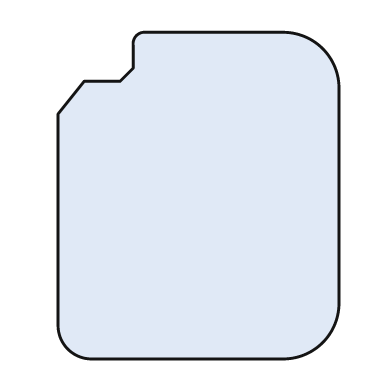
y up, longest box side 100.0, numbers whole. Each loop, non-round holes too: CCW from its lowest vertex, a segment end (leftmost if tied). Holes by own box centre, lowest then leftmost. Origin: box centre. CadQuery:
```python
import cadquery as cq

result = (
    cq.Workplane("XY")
    .moveTo(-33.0, -50.0)
    .lineTo(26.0, -50.0)
    .threePointArc((38.0, -45.0), (43.0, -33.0))
    .lineTo(43.0, 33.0)
    .threePointArc((38.0, 45.0), (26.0, 50.0))
    .lineTo(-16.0, 50.0)
    .threePointArc((-19.0, 49.0), (-20.0, 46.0))
    .lineTo(-20.0, 39.0)
    .lineTo(-24.0, 35.0)
    .lineTo(-35.0, 35.0)
    .lineTo(-43.0, 25.0)
    .lineTo(-43.0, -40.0)
    .threePointArc((-40.0, -47.0), (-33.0, -50.0))
    .close()
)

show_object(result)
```